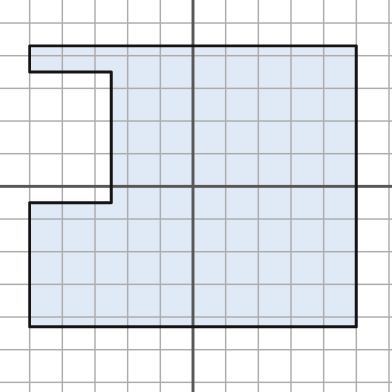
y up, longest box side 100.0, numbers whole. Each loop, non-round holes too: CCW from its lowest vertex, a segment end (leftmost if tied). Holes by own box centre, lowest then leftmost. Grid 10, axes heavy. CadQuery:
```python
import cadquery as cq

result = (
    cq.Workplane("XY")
    .moveTo(-50.0, -43.0)
    .lineTo(50.0, -43.0)
    .lineTo(50.0, 43.0)
    .lineTo(-50.0, 43.0)
    .lineTo(-50.0, 35.0)
    .lineTo(-25.0, 35.0)
    .lineTo(-25.0, -5.0)
    .lineTo(-50.0, -5.0)
    .close()
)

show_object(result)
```